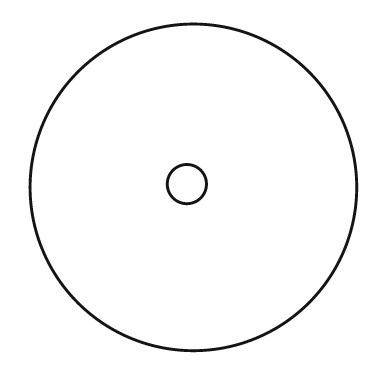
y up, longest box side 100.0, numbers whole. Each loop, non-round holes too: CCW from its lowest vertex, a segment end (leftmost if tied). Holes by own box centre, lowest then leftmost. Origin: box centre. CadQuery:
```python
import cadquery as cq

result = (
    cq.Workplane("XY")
    .moveTo(0.0, 0.0)
    .circle(50.0)
    .moveTo(-2.0, 1.0)
    .circle(6.0)
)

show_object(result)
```